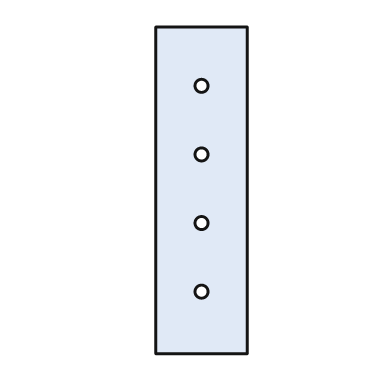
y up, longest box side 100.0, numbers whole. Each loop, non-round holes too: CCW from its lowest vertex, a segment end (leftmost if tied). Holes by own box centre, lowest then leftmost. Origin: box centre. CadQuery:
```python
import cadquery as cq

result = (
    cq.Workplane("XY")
    .moveTo(-14.0, -50.0)
    .lineTo(14.0, -50.0)
    .lineTo(14.0, 50.0)
    .lineTo(-14.0, 50.0)
    .close()
    .moveTo(0.0, -31.0)
    .circle(2.0)
    .moveTo(0.0, -10.0)
    .circle(2.0)
    .moveTo(0.0, 11.0)
    .circle(2.0)
    .moveTo(0.0, 32.0)
    .circle(2.0)
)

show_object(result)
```